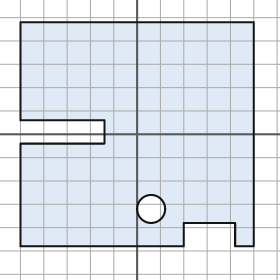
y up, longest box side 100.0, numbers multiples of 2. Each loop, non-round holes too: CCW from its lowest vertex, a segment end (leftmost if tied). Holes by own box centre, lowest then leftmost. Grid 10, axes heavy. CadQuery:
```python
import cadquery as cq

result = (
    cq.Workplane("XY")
    .moveTo(-50.0, -48.0)
    .lineTo(20.0, -48.0)
    .lineTo(20.0, -38.0)
    .lineTo(42.0, -38.0)
    .lineTo(42.0, -48.0)
    .lineTo(50.0, -48.0)
    .lineTo(50.0, 48.0)
    .lineTo(-50.0, 48.0)
    .lineTo(-50.0, 6.0)
    .lineTo(-14.0, 6.0)
    .lineTo(-14.0, -4.0)
    .lineTo(-50.0, -4.0)
    .close()
    .moveTo(6.0, -32.0)
    .circle(6.0)
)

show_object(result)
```